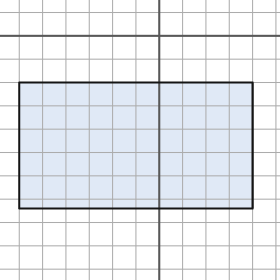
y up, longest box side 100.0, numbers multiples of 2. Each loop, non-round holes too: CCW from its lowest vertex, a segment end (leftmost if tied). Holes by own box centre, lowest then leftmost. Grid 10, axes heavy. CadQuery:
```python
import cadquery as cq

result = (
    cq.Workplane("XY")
    .moveTo(-60.0, -74.0)
    .lineTo(40.0, -74.0)
    .lineTo(40.0, -20.0)
    .lineTo(-60.0, -20.0)
    .close()
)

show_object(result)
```